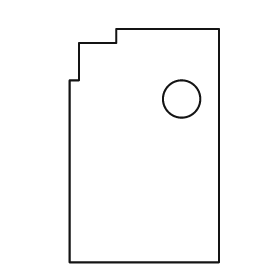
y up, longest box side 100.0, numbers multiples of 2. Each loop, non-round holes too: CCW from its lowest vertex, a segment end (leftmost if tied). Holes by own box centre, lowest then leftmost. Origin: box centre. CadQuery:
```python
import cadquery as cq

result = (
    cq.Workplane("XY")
    .moveTo(-32.0, -50.0)
    .lineTo(32.0, -50.0)
    .lineTo(32.0, 50.0)
    .lineTo(-12.0, 50.0)
    .lineTo(-12.0, 44.0)
    .lineTo(-28.0, 44.0)
    .lineTo(-28.0, 28.0)
    .lineTo(-32.0, 28.0)
    .close()
    .moveTo(16.0, 20.0)
    .circle(8.0)
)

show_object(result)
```